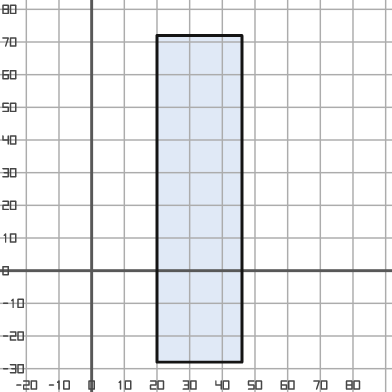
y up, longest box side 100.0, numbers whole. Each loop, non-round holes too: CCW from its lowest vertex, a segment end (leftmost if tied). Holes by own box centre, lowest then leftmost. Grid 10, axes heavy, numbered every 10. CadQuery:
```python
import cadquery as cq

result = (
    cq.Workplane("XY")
    .moveTo(20.0, -28.0)
    .lineTo(46.0, -28.0)
    .lineTo(46.0, 72.0)
    .lineTo(20.0, 72.0)
    .close()
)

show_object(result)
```